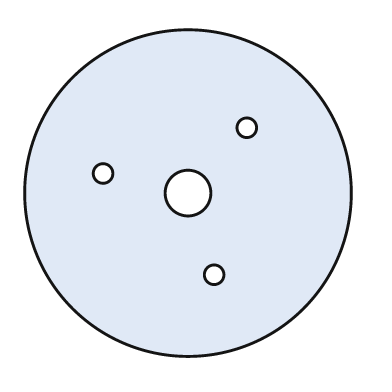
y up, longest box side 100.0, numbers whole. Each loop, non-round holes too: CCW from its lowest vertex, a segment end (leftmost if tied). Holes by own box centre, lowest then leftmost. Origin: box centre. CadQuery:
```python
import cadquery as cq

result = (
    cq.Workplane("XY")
    .moveTo(0.0, 0.0)
    .circle(50.0)
    .moveTo(8.0, -25.0)
    .circle(3.0)
    .moveTo(0.0, 0.0)
    .circle(7.0)
    .moveTo(-26.0, 6.0)
    .circle(3.0)
    .moveTo(18.0, 20.0)
    .circle(3.0)
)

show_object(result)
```